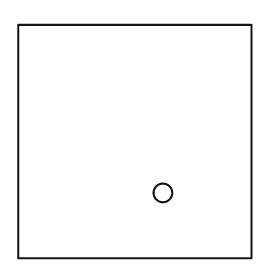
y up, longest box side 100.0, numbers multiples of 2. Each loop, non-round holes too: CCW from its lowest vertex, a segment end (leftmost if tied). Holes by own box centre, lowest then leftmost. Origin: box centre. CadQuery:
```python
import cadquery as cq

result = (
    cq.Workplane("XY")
    .moveTo(-50.0, -50.0)
    .lineTo(50.0, -50.0)
    .lineTo(50.0, 50.0)
    .lineTo(-50.0, 50.0)
    .close()
    .moveTo(12.0, -22.0)
    .circle(4.0)
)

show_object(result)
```